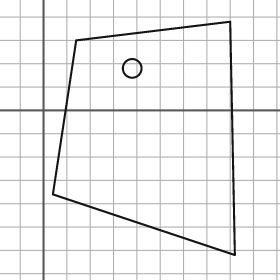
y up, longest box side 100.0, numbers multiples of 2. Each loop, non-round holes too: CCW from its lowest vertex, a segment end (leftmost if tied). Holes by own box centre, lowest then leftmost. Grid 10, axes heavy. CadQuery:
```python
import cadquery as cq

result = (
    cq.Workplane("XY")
    .moveTo(82.0, -62.0)
    .lineTo(80.0, 38.0)
    .lineTo(14.0, 30.0)
    .lineTo(4.0, -36.0)
    .close()
    .moveTo(38.0, 18.0)
    .circle(4.0)
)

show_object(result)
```